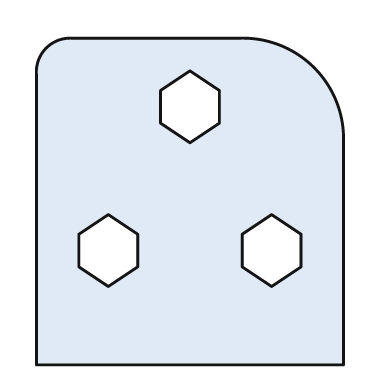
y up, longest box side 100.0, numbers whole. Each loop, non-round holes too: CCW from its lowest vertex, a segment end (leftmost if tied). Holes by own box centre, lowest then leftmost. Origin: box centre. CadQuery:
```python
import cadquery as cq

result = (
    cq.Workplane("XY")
    .moveTo(-47.0, -50.0)
    .lineTo(47.0, -50.0)
    .lineTo(47.0, 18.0)
    .threePointArc((38.0, 41.0), (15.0, 50.0))
    .lineTo(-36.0, 50.0)
    .threePointArc((-44.0, 47.0), (-47.0, 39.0))
    .close()
    .moveTo(-25.0, -26.0)
    .lineTo(-16.0, -20.0)
    .lineTo(-16.0, -10.0)
    .lineTo(-25.0, -4.0)
    .lineTo(-34.0, -10.0)
    .lineTo(-34.0, -20.0)
    .close()
    .moveTo(25.0, -26.0)
    .lineTo(34.0, -20.0)
    .lineTo(34.0, -10.0)
    .lineTo(25.0, -4.0)
    .lineTo(16.0, -10.0)
    .lineTo(16.0, -20.0)
    .close()
    .moveTo(0.0, 18.0)
    .lineTo(9.0, 24.0)
    .lineTo(9.0, 34.0)
    .lineTo(0.0, 40.0)
    .lineTo(-9.0, 34.0)
    .lineTo(-9.0, 24.0)
    .close()
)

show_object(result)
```